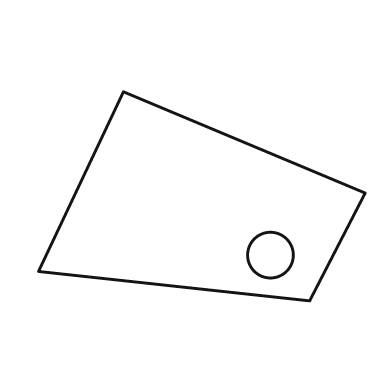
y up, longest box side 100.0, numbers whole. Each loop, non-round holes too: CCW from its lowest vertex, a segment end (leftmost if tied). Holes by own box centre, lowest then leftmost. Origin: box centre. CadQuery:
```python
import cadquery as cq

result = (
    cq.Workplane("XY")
    .moveTo(33.0, -32.0)
    .lineTo(50.0, 1.0)
    .lineTo(-24.0, 32.0)
    .lineTo(-50.0, -23.0)
    .close()
    .moveTo(21.0, -18.0)
    .circle(7.0)
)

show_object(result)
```